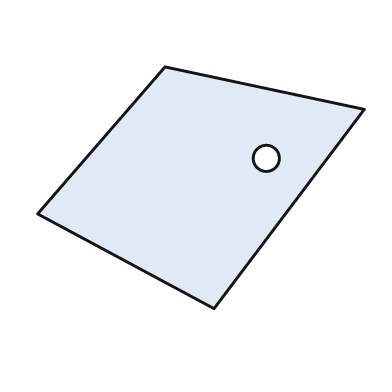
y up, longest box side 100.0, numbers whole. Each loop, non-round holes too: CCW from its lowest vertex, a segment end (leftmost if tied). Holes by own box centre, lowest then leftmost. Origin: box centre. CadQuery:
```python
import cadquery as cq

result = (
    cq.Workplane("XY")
    .moveTo(4.0, -37.0)
    .lineTo(50.0, 24.0)
    .lineTo(-11.0, 37.0)
    .lineTo(-50.0, -8.0)
    .close()
    .moveTo(20.0, 9.0)
    .circle(4.0)
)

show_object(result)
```